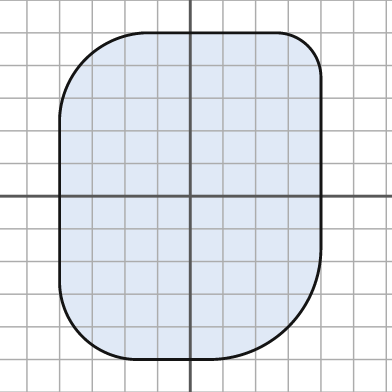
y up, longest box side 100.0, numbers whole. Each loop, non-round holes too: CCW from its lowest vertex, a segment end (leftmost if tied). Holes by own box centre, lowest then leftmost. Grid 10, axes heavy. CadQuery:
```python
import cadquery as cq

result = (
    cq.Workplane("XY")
    .moveTo(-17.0, -50.0)
    .lineTo(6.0, -50.0)
    .threePointArc((30.0, -40.0), (40.0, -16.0))
    .lineTo(40.0, 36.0)
    .threePointArc((36.0, 46.0), (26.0, 50.0))
    .lineTo(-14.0, 50.0)
    .threePointArc((-32.0, 42.0), (-40.0, 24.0))
    .lineTo(-40.0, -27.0)
    .threePointArc((-33.0, -43.0), (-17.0, -50.0))
    .close()
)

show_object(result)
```